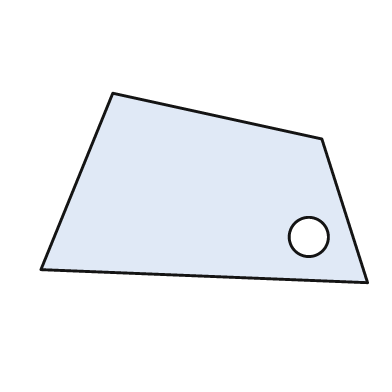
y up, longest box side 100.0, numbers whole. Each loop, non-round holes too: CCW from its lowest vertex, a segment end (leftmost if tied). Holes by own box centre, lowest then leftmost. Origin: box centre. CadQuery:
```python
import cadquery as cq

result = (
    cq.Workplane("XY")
    .moveTo(50.0, -29.0)
    .lineTo(36.0, 15.0)
    .lineTo(-28.0, 29.0)
    .lineTo(-50.0, -25.0)
    .close()
    .moveTo(32.0, -15.0)
    .circle(6.0)
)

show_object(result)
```